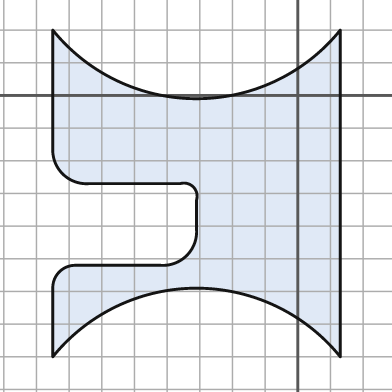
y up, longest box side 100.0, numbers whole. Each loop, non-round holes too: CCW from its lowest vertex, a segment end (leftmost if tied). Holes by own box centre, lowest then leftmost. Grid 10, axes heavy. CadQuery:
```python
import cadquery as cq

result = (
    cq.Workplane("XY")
    .moveTo(-75.0, -80.0)
    .threePointArc((-31.0, -59.0), (13.0, -80.0))
    .lineTo(13.0, 20.0)
    .threePointArc((-31.0, -1.0), (-75.0, 20.0))
    .lineTo(-75.0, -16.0)
    .threePointArc((-72.0, -24.0), (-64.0, -27.0))
    .lineTo(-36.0, -27.0)
    .threePointArc((-32.0, -28.0), (-31.0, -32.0))
    .lineTo(-31.0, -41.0)
    .threePointArc((-34.0, -49.0), (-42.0, -52.0))
    .lineTo(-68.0, -52.0)
    .threePointArc((-73.0, -54.0), (-75.0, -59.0))
    .close()
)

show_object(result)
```